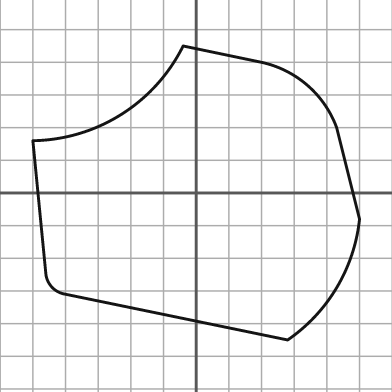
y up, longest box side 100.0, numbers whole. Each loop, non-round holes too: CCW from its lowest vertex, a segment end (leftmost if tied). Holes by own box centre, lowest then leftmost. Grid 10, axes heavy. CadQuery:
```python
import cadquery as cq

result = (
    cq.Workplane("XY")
    .moveTo(28.0, -45.0)
    .threePointArc((43.0, -29.0), (50.0, -8.0))
    .lineTo(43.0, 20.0)
    .threePointArc((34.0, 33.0), (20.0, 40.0))
    .lineTo(-4.0, 45.0)
    .threePointArc((-23.0, 24.0), (-50.0, 16.0))
    .lineTo(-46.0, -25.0)
    .threePointArc((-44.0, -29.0), (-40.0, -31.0))
    .close()
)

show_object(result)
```